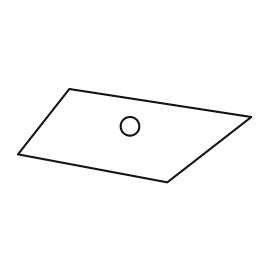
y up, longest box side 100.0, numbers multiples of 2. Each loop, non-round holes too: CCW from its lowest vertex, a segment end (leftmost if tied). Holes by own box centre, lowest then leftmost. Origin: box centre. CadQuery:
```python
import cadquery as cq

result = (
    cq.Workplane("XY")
    .moveTo(14.0, -20.0)
    .lineTo(50.0, 8.0)
    .lineTo(-28.0, 20.0)
    .lineTo(-50.0, -8.0)
    .close()
    .moveTo(-2.0, 4.0)
    .circle(4.0)
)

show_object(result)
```